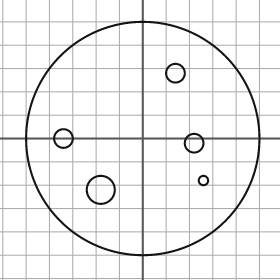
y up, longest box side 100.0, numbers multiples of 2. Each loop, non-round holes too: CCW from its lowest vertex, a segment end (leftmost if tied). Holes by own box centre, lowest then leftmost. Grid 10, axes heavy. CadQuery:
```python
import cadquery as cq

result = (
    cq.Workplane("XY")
    .moveTo(0.0, 0.0)
    .circle(50.0)
    .moveTo(-18.0, -22.0)
    .circle(6.0)
    .moveTo(26.0, -18.0)
    .circle(2.0)
    .moveTo(22.0, -2.0)
    .circle(4.0)
    .moveTo(-34.0, 0.0)
    .circle(4.0)
    .moveTo(14.0, 28.0)
    .circle(4.0)
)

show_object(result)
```